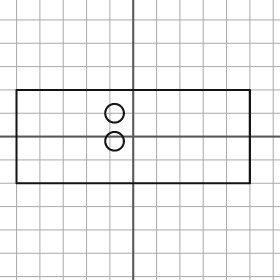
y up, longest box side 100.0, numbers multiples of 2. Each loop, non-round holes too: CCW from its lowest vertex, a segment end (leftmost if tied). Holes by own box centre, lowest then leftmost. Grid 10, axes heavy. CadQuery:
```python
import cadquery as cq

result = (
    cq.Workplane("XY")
    .moveTo(-50.0, -20.0)
    .lineTo(50.0, -20.0)
    .lineTo(50.0, 20.0)
    .lineTo(-50.0, 20.0)
    .close()
    .moveTo(-8.0, -2.0)
    .circle(4.0)
    .moveTo(-8.0, 10.0)
    .circle(4.0)
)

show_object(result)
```